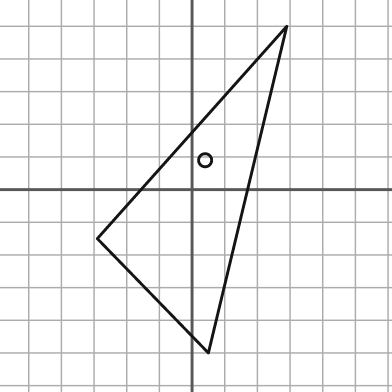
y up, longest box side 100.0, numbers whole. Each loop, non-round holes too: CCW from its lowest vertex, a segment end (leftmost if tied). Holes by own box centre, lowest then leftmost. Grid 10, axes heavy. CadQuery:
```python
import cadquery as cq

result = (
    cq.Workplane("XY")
    .moveTo(5.0, -50.0)
    .lineTo(29.0, 50.0)
    .lineTo(-29.0, -15.0)
    .close()
    .moveTo(4.0, 9.0)
    .circle(2.0)
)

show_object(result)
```